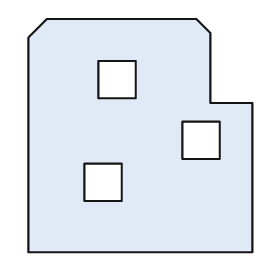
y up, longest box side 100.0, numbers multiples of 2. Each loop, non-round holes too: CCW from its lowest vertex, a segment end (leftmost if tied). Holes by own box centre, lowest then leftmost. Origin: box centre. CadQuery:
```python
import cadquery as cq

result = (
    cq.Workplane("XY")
    .moveTo(-48.0, -50.0)
    .lineTo(48.0, -50.0)
    .lineTo(48.0, 14.0)
    .lineTo(30.0, 14.0)
    .lineTo(30.0, 44.0)
    .lineTo(24.0, 50.0)
    .lineTo(-40.0, 50.0)
    .lineTo(-48.0, 42.0)
    .close()
    .moveTo(-24.0, -28.0)
    .lineTo(-8.0, -28.0)
    .lineTo(-8.0, -12.0)
    .lineTo(-24.0, -12.0)
    .close()
    .moveTo(18.0, -10.0)
    .lineTo(34.0, -10.0)
    .lineTo(34.0, 6.0)
    .lineTo(18.0, 6.0)
    .close()
    .moveTo(-18.0, 16.0)
    .lineTo(-2.0, 16.0)
    .lineTo(-2.0, 32.0)
    .lineTo(-18.0, 32.0)
    .close()
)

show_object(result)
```